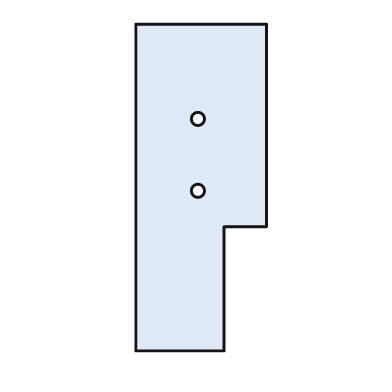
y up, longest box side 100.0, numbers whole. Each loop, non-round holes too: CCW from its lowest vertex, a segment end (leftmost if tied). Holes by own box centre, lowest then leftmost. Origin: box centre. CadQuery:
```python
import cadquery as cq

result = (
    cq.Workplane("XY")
    .moveTo(-20.0, -50.0)
    .lineTo(7.0, -50.0)
    .lineTo(7.0, -12.0)
    .lineTo(20.0, -12.0)
    .lineTo(20.0, 50.0)
    .lineTo(-20.0, 50.0)
    .close()
    .moveTo(-1.0, -1.0)
    .circle(2.0)
    .moveTo(-1.0, 21.0)
    .circle(2.0)
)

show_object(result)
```